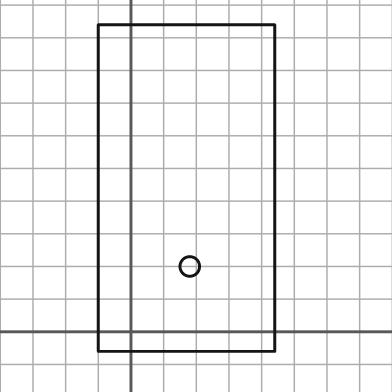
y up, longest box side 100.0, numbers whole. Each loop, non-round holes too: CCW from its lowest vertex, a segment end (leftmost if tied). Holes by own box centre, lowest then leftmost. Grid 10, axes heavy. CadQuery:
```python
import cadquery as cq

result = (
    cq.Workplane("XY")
    .moveTo(-10.0, -6.0)
    .lineTo(44.0, -6.0)
    .lineTo(44.0, 94.0)
    .lineTo(-10.0, 94.0)
    .close()
    .moveTo(18.0, 20.0)
    .circle(3.0)
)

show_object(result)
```